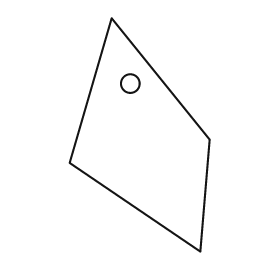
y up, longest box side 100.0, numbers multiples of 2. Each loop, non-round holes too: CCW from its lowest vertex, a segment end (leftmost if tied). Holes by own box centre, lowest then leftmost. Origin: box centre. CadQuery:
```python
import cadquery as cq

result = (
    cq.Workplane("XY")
    .moveTo(26.0, -50.0)
    .lineTo(30.0, -2.0)
    .lineTo(-12.0, 50.0)
    .lineTo(-30.0, -12.0)
    .close()
    .moveTo(-4.0, 22.0)
    .circle(4.0)
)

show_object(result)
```